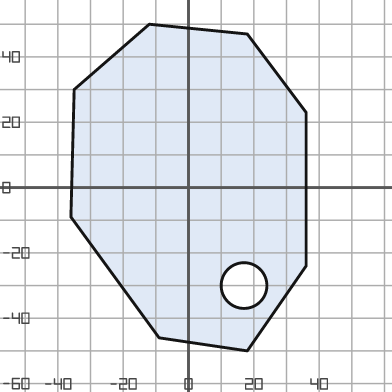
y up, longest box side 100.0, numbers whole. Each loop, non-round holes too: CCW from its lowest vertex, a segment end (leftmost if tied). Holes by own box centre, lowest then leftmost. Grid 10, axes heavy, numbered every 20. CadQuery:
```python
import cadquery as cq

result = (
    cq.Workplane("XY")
    .moveTo(18.0, -50.0)
    .lineTo(36.0, -24.0)
    .lineTo(36.0, 23.0)
    .lineTo(18.0, 47.0)
    .lineTo(-12.0, 50.0)
    .lineTo(-35.0, 30.0)
    .lineTo(-36.0, -9.0)
    .lineTo(-9.0, -46.0)
    .close()
    .moveTo(17.0, -30.0)
    .circle(7.0)
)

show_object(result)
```